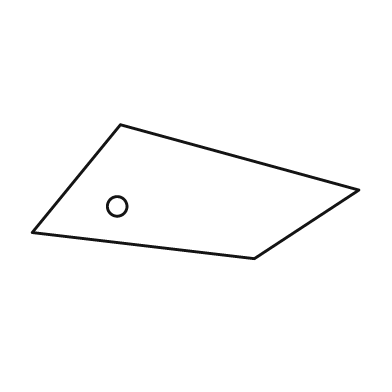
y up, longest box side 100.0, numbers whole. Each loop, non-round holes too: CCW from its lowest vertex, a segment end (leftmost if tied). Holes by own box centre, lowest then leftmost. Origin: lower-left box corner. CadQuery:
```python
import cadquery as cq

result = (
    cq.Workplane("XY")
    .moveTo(68.0, 0.0)
    .lineTo(100.0, 21.0)
    .lineTo(27.0, 41.0)
    .lineTo(0.0, 8.0)
    .close()
    .moveTo(26.0, 16.0)
    .circle(3.0)
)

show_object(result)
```